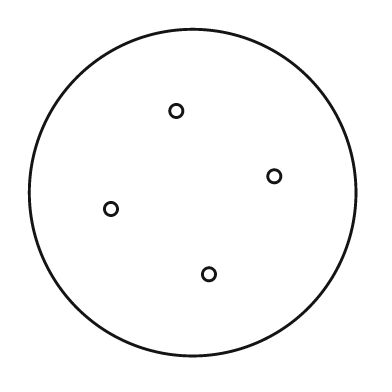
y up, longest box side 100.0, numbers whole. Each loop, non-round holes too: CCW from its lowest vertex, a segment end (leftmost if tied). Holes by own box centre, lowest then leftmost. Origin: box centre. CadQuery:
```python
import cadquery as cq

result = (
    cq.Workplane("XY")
    .moveTo(0.0, 0.0)
    .circle(50.0)
    .moveTo(5.0, -25.0)
    .circle(2.0)
    .moveTo(-25.0, -5.0)
    .circle(2.0)
    .moveTo(25.0, 5.0)
    .circle(2.0)
    .moveTo(-5.0, 25.0)
    .circle(2.0)
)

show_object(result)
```